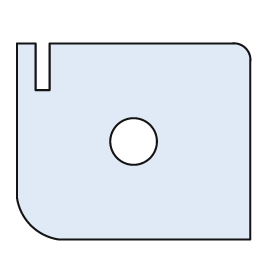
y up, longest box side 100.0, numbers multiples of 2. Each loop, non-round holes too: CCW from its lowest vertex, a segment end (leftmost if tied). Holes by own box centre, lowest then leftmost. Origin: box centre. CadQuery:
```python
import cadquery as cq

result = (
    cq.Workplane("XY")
    .moveTo(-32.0, -42.0)
    .lineTo(50.0, -42.0)
    .lineTo(50.0, 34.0)
    .threePointArc((48.0, 40.0), (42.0, 42.0))
    .lineTo(-36.0, 42.0)
    .lineTo(-36.0, 22.0)
    .lineTo(-42.0, 22.0)
    .lineTo(-42.0, 42.0)
    .lineTo(-50.0, 42.0)
    .lineTo(-50.0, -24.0)
    .threePointArc((-44.0, -36.0), (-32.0, -42.0))
    .close()
    .moveTo(0.0, 0.0)
    .circle(10.0)
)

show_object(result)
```